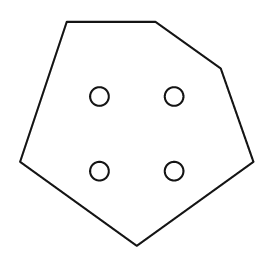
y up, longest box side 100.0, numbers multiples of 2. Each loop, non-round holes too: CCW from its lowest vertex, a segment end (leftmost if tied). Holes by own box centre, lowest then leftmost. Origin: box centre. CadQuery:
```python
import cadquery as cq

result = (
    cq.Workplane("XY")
    .moveTo(0.0, -48.0)
    .lineTo(50.0, -12.0)
    .lineTo(36.0, 28.0)
    .lineTo(8.0, 48.0)
    .lineTo(-30.0, 48.0)
    .lineTo(-50.0, -12.0)
    .close()
    .moveTo(-16.0, -16.0)
    .circle(4.0)
    .moveTo(16.0, -16.0)
    .circle(4.0)
    .moveTo(-16.0, 16.0)
    .circle(4.0)
    .moveTo(16.0, 16.0)
    .circle(4.0)
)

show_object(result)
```